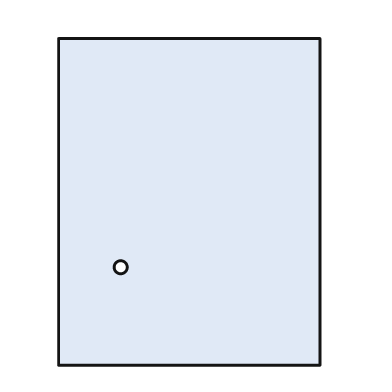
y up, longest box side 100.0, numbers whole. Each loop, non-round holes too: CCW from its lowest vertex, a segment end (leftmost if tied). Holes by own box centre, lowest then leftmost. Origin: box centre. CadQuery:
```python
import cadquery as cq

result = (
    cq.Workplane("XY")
    .moveTo(-40.0, -50.0)
    .lineTo(40.0, -50.0)
    .lineTo(40.0, 50.0)
    .lineTo(-40.0, 50.0)
    .close()
    .moveTo(-21.0, -20.0)
    .circle(2.0)
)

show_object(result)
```